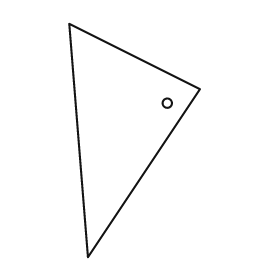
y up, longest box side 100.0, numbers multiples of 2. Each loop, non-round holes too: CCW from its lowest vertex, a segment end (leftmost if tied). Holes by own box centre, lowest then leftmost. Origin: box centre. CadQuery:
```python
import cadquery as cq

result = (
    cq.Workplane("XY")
    .moveTo(-20.0, -50.0)
    .lineTo(28.0, 22.0)
    .lineTo(-28.0, 50.0)
    .close()
    .moveTo(14.0, 16.0)
    .circle(2.0)
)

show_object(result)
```